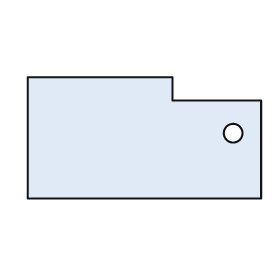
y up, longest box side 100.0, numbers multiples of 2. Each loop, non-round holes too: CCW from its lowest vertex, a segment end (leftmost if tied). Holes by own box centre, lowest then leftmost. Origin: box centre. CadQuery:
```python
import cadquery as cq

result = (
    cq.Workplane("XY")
    .moveTo(-50.0, -26.0)
    .lineTo(50.0, -26.0)
    .lineTo(50.0, 16.0)
    .lineTo(12.0, 16.0)
    .lineTo(12.0, 26.0)
    .lineTo(-50.0, 26.0)
    .close()
    .moveTo(38.0, 2.0)
    .circle(4.0)
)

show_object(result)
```